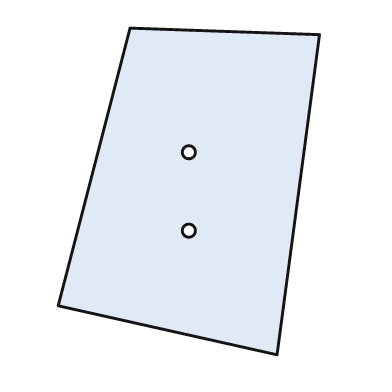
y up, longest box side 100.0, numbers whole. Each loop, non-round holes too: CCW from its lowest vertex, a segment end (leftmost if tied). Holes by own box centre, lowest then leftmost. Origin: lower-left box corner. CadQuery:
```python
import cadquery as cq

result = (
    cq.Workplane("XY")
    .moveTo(67.0, 0.0)
    .lineTo(80.0, 98.0)
    .lineTo(22.0, 100.0)
    .lineTo(0.0, 15.0)
    .close()
    .moveTo(40.0, 38.0)
    .circle(2.0)
    .moveTo(40.0, 62.0)
    .circle(2.0)
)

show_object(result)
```